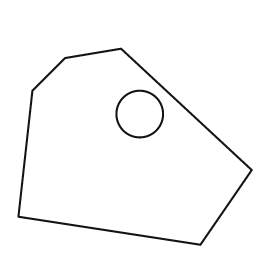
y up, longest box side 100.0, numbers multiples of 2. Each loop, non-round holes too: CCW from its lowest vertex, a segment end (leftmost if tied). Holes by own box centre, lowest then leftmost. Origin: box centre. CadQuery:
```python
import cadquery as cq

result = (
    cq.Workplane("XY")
    .moveTo(28.0, -42.0)
    .lineTo(50.0, -10.0)
    .lineTo(-6.0, 42.0)
    .lineTo(-30.0, 38.0)
    .lineTo(-44.0, 24.0)
    .lineTo(-50.0, -30.0)
    .close()
    .moveTo(2.0, 14.0)
    .circle(10.0)
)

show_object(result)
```